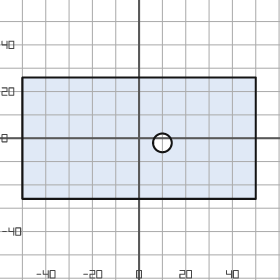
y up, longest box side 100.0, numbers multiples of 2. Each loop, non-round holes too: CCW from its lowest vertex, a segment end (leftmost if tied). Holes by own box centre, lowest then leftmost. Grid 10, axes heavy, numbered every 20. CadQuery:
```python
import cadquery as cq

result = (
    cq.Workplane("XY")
    .moveTo(-50.0, -26.0)
    .lineTo(50.0, -26.0)
    .lineTo(50.0, 26.0)
    .lineTo(-50.0, 26.0)
    .close()
    .moveTo(10.0, -2.0)
    .circle(4.0)
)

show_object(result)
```